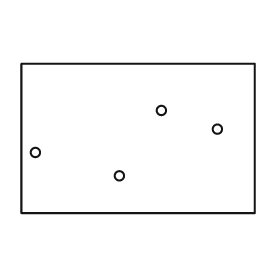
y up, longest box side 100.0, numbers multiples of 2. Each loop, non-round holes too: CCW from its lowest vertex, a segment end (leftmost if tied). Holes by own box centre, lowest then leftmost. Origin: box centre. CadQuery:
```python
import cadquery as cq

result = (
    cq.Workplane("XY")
    .moveTo(-50.0, -32.0)
    .lineTo(50.0, -32.0)
    .lineTo(50.0, 32.0)
    .lineTo(-50.0, 32.0)
    .close()
    .moveTo(-8.0, -16.0)
    .circle(2.0)
    .moveTo(-44.0, -6.0)
    .circle(2.0)
    .moveTo(34.0, 4.0)
    .circle(2.0)
    .moveTo(10.0, 12.0)
    .circle(2.0)
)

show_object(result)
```